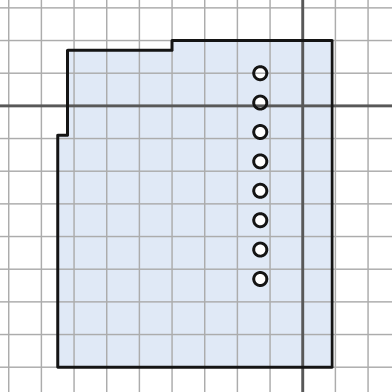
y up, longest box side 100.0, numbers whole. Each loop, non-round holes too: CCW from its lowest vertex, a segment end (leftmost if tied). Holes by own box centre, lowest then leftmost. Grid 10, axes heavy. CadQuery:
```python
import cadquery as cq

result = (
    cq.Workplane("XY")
    .moveTo(-75.0, -80.0)
    .lineTo(9.0, -80.0)
    .lineTo(9.0, 20.0)
    .lineTo(-40.0, 20.0)
    .lineTo(-40.0, 17.0)
    .lineTo(-72.0, 17.0)
    .lineTo(-72.0, -9.0)
    .lineTo(-75.0, -9.0)
    .close()
    .moveTo(-13.0, -53.0)
    .circle(2.0)
    .moveTo(-13.0, -44.0)
    .circle(2.0)
    .moveTo(-13.0, -35.0)
    .circle(2.0)
    .moveTo(-13.0, -26.0)
    .circle(2.0)
    .moveTo(-13.0, -17.0)
    .circle(2.0)
    .moveTo(-13.0, -8.0)
    .circle(2.0)
    .moveTo(-13.0, 1.0)
    .circle(2.0)
    .moveTo(-13.0, 10.0)
    .circle(2.0)
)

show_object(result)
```